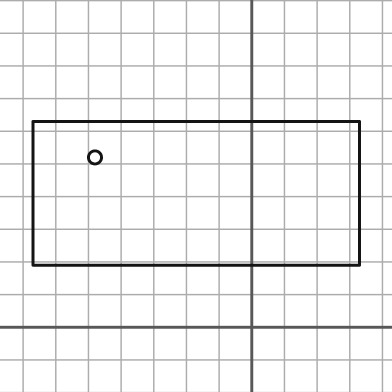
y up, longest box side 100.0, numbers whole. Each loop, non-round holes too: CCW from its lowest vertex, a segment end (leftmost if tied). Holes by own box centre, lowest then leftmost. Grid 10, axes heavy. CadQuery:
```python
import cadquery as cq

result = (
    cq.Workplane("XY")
    .moveTo(-67.0, 19.0)
    .lineTo(33.0, 19.0)
    .lineTo(33.0, 63.0)
    .lineTo(-67.0, 63.0)
    .close()
    .moveTo(-48.0, 52.0)
    .circle(2.0)
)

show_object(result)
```